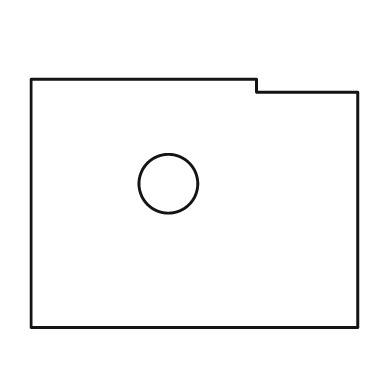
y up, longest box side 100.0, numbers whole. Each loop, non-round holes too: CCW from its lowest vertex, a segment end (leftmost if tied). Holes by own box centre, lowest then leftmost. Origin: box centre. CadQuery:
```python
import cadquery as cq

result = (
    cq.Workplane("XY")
    .moveTo(-50.0, -38.0)
    .lineTo(50.0, -38.0)
    .lineTo(50.0, 34.0)
    .lineTo(19.0, 34.0)
    .lineTo(19.0, 38.0)
    .lineTo(-50.0, 38.0)
    .close()
    .moveTo(-8.0, 6.0)
    .circle(9.0)
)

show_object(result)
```